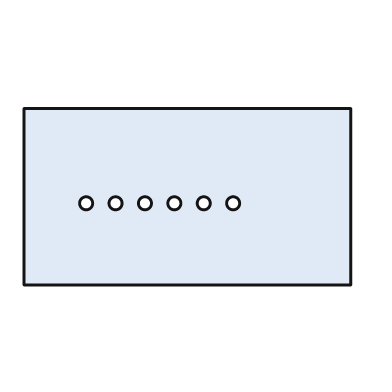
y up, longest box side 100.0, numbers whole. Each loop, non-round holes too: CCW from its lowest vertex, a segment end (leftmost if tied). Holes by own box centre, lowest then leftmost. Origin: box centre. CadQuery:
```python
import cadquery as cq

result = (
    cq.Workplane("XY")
    .moveTo(-50.0, -27.0)
    .lineTo(50.0, -27.0)
    .lineTo(50.0, 27.0)
    .lineTo(-50.0, 27.0)
    .close()
    .moveTo(-31.0, -2.0)
    .circle(2.0)
    .moveTo(-22.0, -2.0)
    .circle(2.0)
    .moveTo(-13.0, -2.0)
    .circle(2.0)
    .moveTo(-4.0, -2.0)
    .circle(2.0)
    .moveTo(5.0, -2.0)
    .circle(2.0)
    .moveTo(14.0, -2.0)
    .circle(2.0)
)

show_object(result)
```